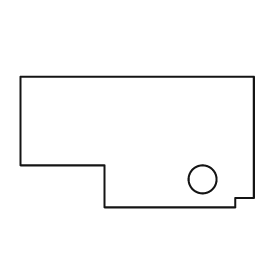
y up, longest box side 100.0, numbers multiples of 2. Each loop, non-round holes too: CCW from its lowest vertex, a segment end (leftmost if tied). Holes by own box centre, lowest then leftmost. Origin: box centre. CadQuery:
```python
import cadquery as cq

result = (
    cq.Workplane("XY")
    .moveTo(-14.0, -28.0)
    .lineTo(42.0, -28.0)
    .lineTo(42.0, -24.0)
    .lineTo(50.0, -24.0)
    .lineTo(50.0, 28.0)
    .lineTo(-50.0, 28.0)
    .lineTo(-50.0, -10.0)
    .lineTo(-14.0, -10.0)
    .close()
    .moveTo(28.0, -16.0)
    .circle(6.0)
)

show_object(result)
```